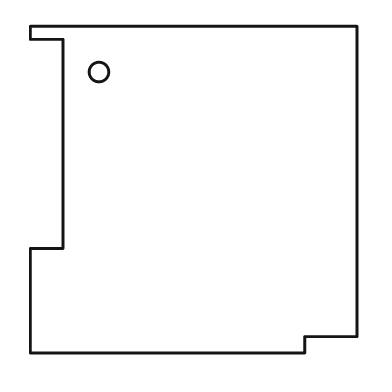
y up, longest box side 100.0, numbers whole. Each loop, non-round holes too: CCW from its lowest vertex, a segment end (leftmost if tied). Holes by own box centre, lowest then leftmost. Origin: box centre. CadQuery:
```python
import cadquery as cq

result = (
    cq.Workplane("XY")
    .moveTo(-50.0, -50.0)
    .lineTo(34.0, -50.0)
    .lineTo(34.0, -45.0)
    .lineTo(50.0, -45.0)
    .lineTo(50.0, 50.0)
    .lineTo(-50.0, 50.0)
    .lineTo(-50.0, 46.0)
    .lineTo(-40.0, 46.0)
    .lineTo(-40.0, -18.0)
    .lineTo(-50.0, -18.0)
    .close()
    .moveTo(-29.0, 36.0)
    .circle(3.0)
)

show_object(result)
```